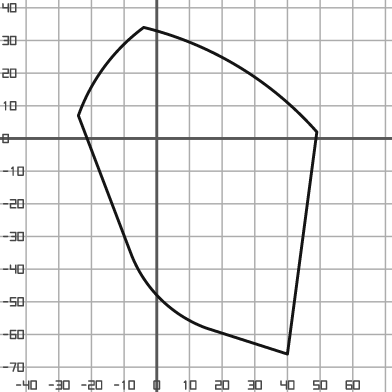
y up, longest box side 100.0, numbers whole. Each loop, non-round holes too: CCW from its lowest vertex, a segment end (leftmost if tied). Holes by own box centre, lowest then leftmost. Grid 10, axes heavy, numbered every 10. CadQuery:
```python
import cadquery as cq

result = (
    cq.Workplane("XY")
    .moveTo(40.0, -66.0)
    .lineTo(49.0, 2.0)
    .threePointArc((25.0, 22.0), (-4.0, 34.0))
    .threePointArc((-16.0, 22.0), (-24.0, 7.0))
    .lineTo(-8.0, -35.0)
    .threePointArc((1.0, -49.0), (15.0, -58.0))
    .close()
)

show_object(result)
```